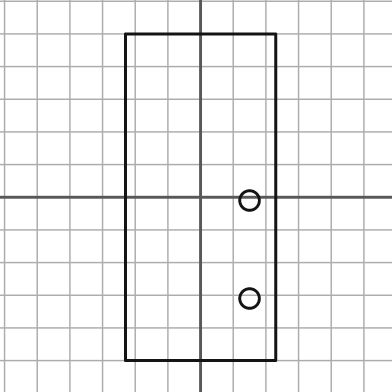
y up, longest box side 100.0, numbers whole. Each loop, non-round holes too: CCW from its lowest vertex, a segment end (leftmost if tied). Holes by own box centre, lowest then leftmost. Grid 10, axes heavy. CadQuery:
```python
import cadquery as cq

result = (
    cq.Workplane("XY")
    .moveTo(-23.0, -50.0)
    .lineTo(23.0, -50.0)
    .lineTo(23.0, 50.0)
    .lineTo(-23.0, 50.0)
    .close()
    .moveTo(15.0, -31.0)
    .circle(3.0)
    .moveTo(15.0, -1.0)
    .circle(3.0)
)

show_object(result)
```